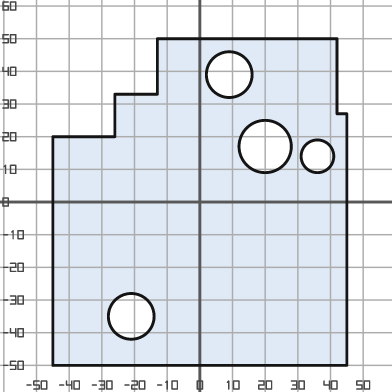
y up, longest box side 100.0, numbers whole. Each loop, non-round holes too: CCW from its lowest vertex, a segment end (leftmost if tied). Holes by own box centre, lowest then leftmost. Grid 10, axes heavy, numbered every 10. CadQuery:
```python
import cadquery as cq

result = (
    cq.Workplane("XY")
    .moveTo(-45.0, -50.0)
    .lineTo(45.0, -50.0)
    .lineTo(45.0, 27.0)
    .lineTo(42.0, 27.0)
    .lineTo(42.0, 50.0)
    .lineTo(-13.0, 50.0)
    .lineTo(-13.0, 33.0)
    .lineTo(-26.0, 33.0)
    .lineTo(-26.0, 20.0)
    .lineTo(-45.0, 20.0)
    .close()
    .moveTo(-21.0, -35.0)
    .circle(7.0)
    .moveTo(36.0, 14.0)
    .circle(5.0)
    .moveTo(20.0, 17.0)
    .circle(8.0)
    .moveTo(9.0, 39.0)
    .circle(7.0)
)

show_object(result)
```